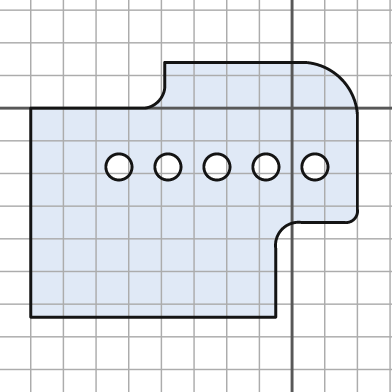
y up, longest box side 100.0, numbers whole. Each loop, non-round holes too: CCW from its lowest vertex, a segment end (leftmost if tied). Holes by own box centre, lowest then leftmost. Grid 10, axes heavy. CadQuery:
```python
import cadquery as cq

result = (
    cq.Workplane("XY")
    .moveTo(-80.0, -64.0)
    .lineTo(-5.0, -64.0)
    .lineTo(-5.0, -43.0)
    .threePointArc((-3.0, -37.0), (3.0, -35.0))
    .lineTo(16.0, -35.0)
    .threePointArc((19.0, -34.0), (20.0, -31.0))
    .lineTo(20.0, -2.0)
    .threePointArc((15.0, 9.0), (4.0, 14.0))
    .lineTo(-39.0, 14.0)
    .lineTo(-39.0, 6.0)
    .threePointArc((-41.0, 2.0), (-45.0, 0.0))
    .lineTo(-80.0, 0.0)
    .close()
    .moveTo(-53.0, -18.0)
    .circle(4.0)
    .moveTo(-38.0, -18.0)
    .circle(4.0)
    .moveTo(-23.0, -18.0)
    .circle(4.0)
    .moveTo(-8.0, -18.0)
    .circle(4.0)
    .moveTo(7.0, -18.0)
    .circle(4.0)
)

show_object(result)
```